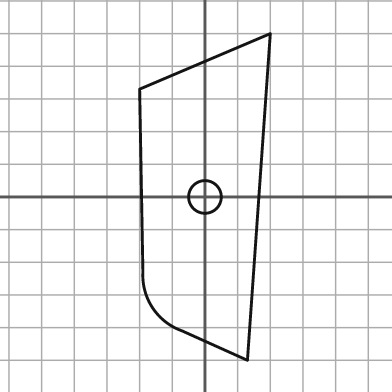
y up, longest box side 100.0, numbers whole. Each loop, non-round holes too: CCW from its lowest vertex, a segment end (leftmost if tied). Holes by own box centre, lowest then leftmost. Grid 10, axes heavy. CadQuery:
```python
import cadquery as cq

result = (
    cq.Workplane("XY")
    .moveTo(13.0, -50.0)
    .lineTo(20.0, 50.0)
    .lineTo(-20.0, 33.0)
    .lineTo(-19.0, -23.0)
    .threePointArc((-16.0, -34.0), (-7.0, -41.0))
    .close()
    .moveTo(0.0, 0.0)
    .circle(5.0)
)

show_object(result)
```